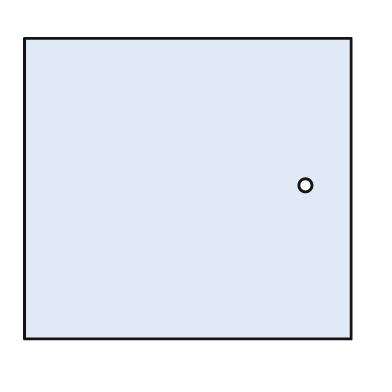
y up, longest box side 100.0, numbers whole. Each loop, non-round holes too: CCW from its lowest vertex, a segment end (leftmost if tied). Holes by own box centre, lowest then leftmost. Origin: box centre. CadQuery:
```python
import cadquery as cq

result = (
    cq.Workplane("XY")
    .moveTo(-50.0, -46.0)
    .lineTo(50.0, -46.0)
    .lineTo(50.0, 46.0)
    .lineTo(-50.0, 46.0)
    .close()
    .moveTo(36.0, 1.0)
    .circle(2.0)
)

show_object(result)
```